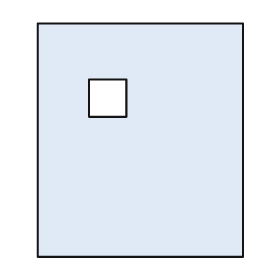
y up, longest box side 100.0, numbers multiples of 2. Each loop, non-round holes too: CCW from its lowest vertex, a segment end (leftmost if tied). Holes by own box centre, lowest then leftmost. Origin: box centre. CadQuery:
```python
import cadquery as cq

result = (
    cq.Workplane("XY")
    .moveTo(-44.0, -50.0)
    .lineTo(44.0, -50.0)
    .lineTo(44.0, 50.0)
    .lineTo(-44.0, 50.0)
    .close()
    .moveTo(-22.0, 10.0)
    .lineTo(-6.0, 10.0)
    .lineTo(-6.0, 26.0)
    .lineTo(-22.0, 26.0)
    .close()
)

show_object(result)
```